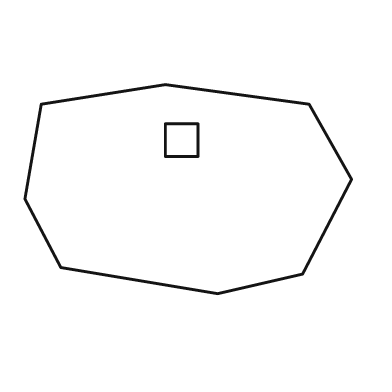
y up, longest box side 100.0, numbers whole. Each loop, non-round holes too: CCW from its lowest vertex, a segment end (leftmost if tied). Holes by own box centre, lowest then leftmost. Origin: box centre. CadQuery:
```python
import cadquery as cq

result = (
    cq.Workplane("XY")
    .moveTo(9.0, -32.0)
    .lineTo(35.0, -26.0)
    .lineTo(50.0, 3.0)
    .lineTo(37.0, 26.0)
    .lineTo(-7.0, 32.0)
    .lineTo(-45.0, 26.0)
    .lineTo(-50.0, -3.0)
    .lineTo(-39.0, -24.0)
    .close()
    .moveTo(-7.0, 10.0)
    .lineTo(3.0, 10.0)
    .lineTo(3.0, 20.0)
    .lineTo(-7.0, 20.0)
    .close()
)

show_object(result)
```